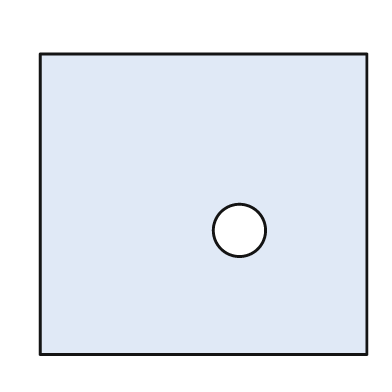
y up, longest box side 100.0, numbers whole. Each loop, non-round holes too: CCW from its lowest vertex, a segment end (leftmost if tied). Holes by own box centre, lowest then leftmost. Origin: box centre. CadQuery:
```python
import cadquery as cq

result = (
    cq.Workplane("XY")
    .moveTo(-50.0, -46.0)
    .lineTo(50.0, -46.0)
    .lineTo(50.0, 46.0)
    .lineTo(-50.0, 46.0)
    .close()
    .moveTo(11.0, -8.0)
    .circle(8.0)
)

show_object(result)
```